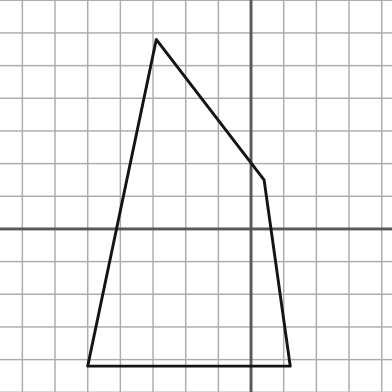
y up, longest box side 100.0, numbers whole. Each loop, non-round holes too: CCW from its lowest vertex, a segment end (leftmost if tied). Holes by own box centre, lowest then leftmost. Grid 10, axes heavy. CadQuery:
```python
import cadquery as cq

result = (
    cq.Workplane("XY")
    .moveTo(-50.0, -42.0)
    .lineTo(12.0, -42.0)
    .lineTo(4.0, 15.0)
    .lineTo(-29.0, 58.0)
    .close()
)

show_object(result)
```